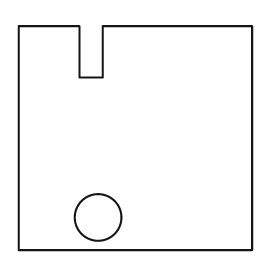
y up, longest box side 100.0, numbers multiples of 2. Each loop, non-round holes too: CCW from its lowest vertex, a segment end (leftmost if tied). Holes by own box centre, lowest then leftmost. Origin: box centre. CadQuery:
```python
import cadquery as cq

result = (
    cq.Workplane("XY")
    .moveTo(-50.0, -48.0)
    .lineTo(50.0, -48.0)
    .lineTo(50.0, 48.0)
    .lineTo(-14.0, 48.0)
    .lineTo(-14.0, 26.0)
    .lineTo(-24.0, 26.0)
    .lineTo(-24.0, 48.0)
    .lineTo(-50.0, 48.0)
    .close()
    .moveTo(-16.0, -34.0)
    .circle(10.0)
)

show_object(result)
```